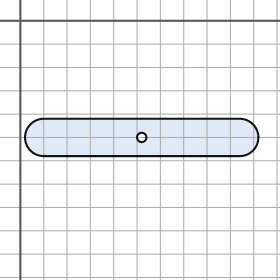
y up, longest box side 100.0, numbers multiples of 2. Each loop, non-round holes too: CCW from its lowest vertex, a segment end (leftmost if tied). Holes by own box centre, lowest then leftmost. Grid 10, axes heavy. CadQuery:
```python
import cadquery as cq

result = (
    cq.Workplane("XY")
    .moveTo(10.0, -58.0)
    .lineTo(94.0, -58.0)
    .threePointArc((102.0, -50.0), (94.0, -42.0))
    .lineTo(10.0, -42.0)
    .threePointArc((2.0, -50.0), (10.0, -58.0))
    .close()
    .moveTo(52.0, -50.0)
    .circle(2.0)
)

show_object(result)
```